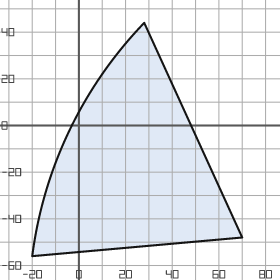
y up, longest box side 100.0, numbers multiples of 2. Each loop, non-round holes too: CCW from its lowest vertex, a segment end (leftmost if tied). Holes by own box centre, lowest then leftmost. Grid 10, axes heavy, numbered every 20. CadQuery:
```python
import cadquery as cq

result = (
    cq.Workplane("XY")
    .moveTo(-20.0, -56.0)
    .lineTo(70.0, -48.0)
    .lineTo(28.0, 44.0)
    .threePointArc((-4.0, -2.0), (-20.0, -56.0))
    .close()
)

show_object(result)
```